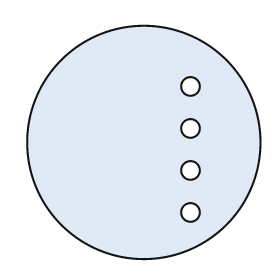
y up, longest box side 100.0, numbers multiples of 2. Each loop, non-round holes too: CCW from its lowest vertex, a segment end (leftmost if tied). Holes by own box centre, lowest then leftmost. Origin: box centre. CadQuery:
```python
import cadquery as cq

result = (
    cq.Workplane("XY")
    .moveTo(0.0, 0.0)
    .circle(50.0)
    .moveTo(20.0, -30.0)
    .circle(4.0)
    .moveTo(20.0, -12.0)
    .circle(4.0)
    .moveTo(20.0, 6.0)
    .circle(4.0)
    .moveTo(20.0, 24.0)
    .circle(4.0)
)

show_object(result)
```